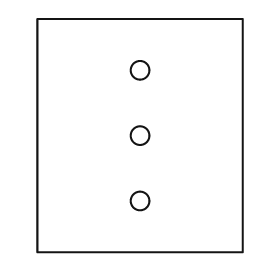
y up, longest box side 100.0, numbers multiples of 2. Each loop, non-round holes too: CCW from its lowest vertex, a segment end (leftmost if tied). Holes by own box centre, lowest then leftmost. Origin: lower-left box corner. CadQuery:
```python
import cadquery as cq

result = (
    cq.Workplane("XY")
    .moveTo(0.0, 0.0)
    .lineTo(88.0, 0.0)
    .lineTo(88.0, 100.0)
    .lineTo(0.0, 100.0)
    .close()
    .moveTo(44.0, 22.0)
    .circle(4.0)
    .moveTo(44.0, 50.0)
    .circle(4.0)
    .moveTo(44.0, 78.0)
    .circle(4.0)
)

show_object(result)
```